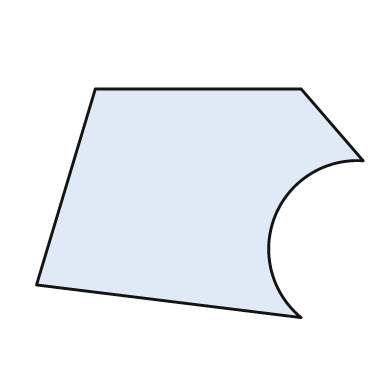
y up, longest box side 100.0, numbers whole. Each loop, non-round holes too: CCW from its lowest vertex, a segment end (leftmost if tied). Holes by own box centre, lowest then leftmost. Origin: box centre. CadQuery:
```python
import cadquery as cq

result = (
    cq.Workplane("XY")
    .moveTo(31.0, -35.0)
    .threePointArc((23.0, -4.0), (50.0, 13.0))
    .lineTo(31.0, 35.0)
    .lineTo(-32.0, 35.0)
    .lineTo(-50.0, -25.0)
    .close()
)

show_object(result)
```